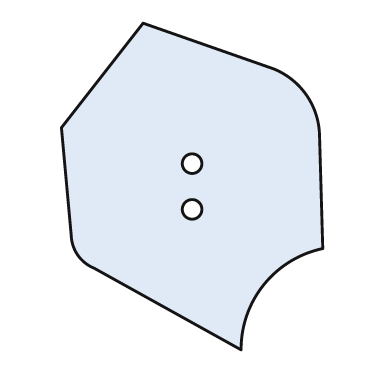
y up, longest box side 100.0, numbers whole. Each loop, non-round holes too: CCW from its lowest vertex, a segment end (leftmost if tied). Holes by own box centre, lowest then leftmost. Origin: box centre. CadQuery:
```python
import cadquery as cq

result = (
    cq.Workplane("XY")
    .moveTo(15.0, -50.0)
    .threePointArc((22.0, -30.0), (40.0, -19.0))
    .lineTo(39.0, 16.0)
    .threePointArc((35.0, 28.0), (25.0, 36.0))
    .lineTo(-15.0, 50.0)
    .lineTo(-40.0, 18.0)
    .lineTo(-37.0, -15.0)
    .threePointArc((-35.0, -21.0), (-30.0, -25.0))
    .close()
    .moveTo(0.0, -7.0)
    .circle(3.0)
    .moveTo(0.0, 7.0)
    .circle(3.0)
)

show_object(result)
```